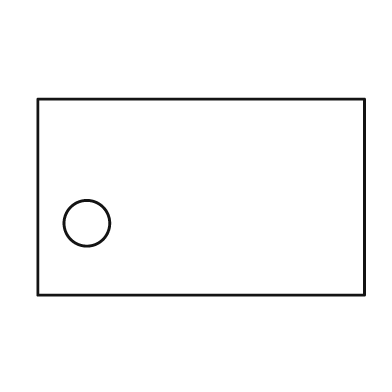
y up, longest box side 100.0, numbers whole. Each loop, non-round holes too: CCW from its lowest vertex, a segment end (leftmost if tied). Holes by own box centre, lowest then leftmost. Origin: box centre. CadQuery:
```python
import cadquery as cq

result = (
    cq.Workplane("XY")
    .moveTo(-50.0, -30.0)
    .lineTo(50.0, -30.0)
    .lineTo(50.0, 30.0)
    .lineTo(-50.0, 30.0)
    .close()
    .moveTo(-35.0, -8.0)
    .circle(7.0)
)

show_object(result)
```